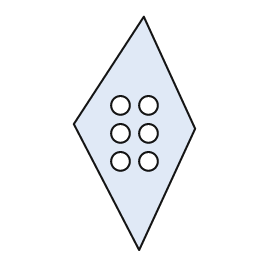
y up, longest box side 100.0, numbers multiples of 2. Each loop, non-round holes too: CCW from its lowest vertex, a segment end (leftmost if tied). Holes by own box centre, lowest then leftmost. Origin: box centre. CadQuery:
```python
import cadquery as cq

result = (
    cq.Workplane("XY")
    .moveTo(2.0, -50.0)
    .lineTo(26.0, 2.0)
    .lineTo(4.0, 50.0)
    .lineTo(-26.0, 4.0)
    .close()
    .moveTo(-6.0, -12.0)
    .circle(4.0)
    .moveTo(6.0, -12.0)
    .circle(4.0)
    .moveTo(-6.0, 0.0)
    .circle(4.0)
    .moveTo(6.0, 0.0)
    .circle(4.0)
    .moveTo(-6.0, 12.0)
    .circle(4.0)
    .moveTo(6.0, 12.0)
    .circle(4.0)
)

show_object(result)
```